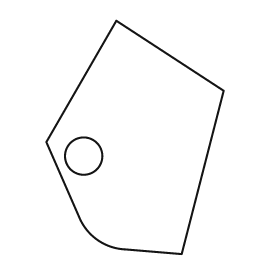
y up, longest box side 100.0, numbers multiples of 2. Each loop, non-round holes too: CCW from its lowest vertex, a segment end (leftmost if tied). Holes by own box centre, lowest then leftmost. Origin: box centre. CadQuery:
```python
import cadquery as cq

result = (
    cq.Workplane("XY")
    .moveTo(20.0, -50.0)
    .lineTo(38.0, 20.0)
    .lineTo(-8.0, 50.0)
    .lineTo(-38.0, -2.0)
    .lineTo(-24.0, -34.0)
    .threePointArc((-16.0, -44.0), (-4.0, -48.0))
    .close()
    .moveTo(-22.0, -8.0)
    .circle(8.0)
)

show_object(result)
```